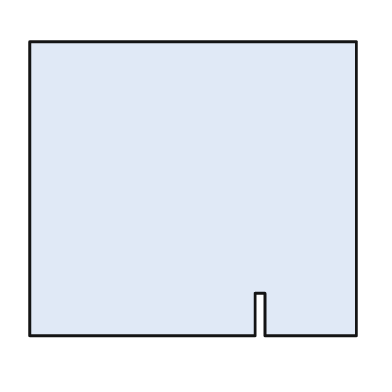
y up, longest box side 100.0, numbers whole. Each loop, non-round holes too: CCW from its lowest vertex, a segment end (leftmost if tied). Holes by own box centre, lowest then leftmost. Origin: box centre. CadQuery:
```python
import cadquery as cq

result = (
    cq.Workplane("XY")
    .moveTo(-50.0, -45.0)
    .lineTo(19.0, -45.0)
    .lineTo(19.0, -32.0)
    .lineTo(22.0, -32.0)
    .lineTo(22.0, -45.0)
    .lineTo(50.0, -45.0)
    .lineTo(50.0, 45.0)
    .lineTo(-50.0, 45.0)
    .close()
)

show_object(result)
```